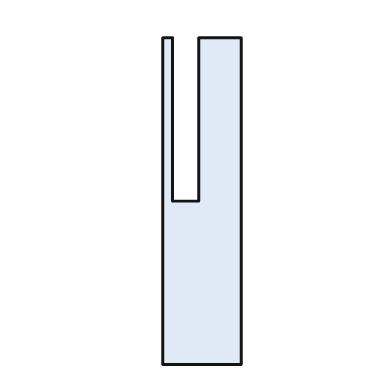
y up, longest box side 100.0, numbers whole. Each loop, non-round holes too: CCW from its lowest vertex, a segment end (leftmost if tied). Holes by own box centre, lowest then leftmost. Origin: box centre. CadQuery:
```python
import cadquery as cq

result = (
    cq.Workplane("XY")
    .moveTo(-12.0, -50.0)
    .lineTo(12.0, -50.0)
    .lineTo(12.0, 50.0)
    .lineTo(-1.0, 50.0)
    .lineTo(-1.0, 0.0)
    .lineTo(-9.0, 0.0)
    .lineTo(-9.0, 50.0)
    .lineTo(-12.0, 50.0)
    .close()
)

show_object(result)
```